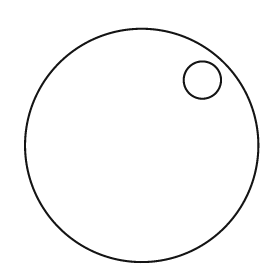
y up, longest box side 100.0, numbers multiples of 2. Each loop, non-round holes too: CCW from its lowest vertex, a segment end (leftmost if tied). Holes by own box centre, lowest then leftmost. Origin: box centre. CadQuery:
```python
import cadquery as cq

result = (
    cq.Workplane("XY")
    .moveTo(0.0, 0.0)
    .circle(50.0)
    .moveTo(26.0, 28.0)
    .circle(8.0)
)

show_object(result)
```